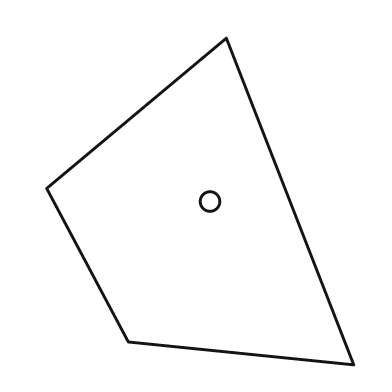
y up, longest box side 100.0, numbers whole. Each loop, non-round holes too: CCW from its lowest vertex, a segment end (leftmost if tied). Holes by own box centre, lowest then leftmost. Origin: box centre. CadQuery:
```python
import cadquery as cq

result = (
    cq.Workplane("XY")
    .moveTo(47.0, -50.0)
    .lineTo(8.0, 50.0)
    .lineTo(-47.0, 4.0)
    .lineTo(-22.0, -43.0)
    .close()
    .moveTo(3.0, 0.0)
    .circle(3.0)
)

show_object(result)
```